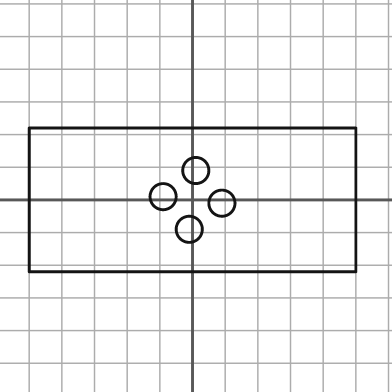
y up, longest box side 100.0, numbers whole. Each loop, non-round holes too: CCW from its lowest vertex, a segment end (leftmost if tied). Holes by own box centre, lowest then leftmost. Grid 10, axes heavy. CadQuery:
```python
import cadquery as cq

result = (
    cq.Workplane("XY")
    .moveTo(-50.0, -22.0)
    .lineTo(50.0, -22.0)
    .lineTo(50.0, 22.0)
    .lineTo(-50.0, 22.0)
    .close()
    .moveTo(-1.0, -9.0)
    .circle(4.0)
    .moveTo(9.0, -1.0)
    .circle(4.0)
    .moveTo(-9.0, 1.0)
    .circle(4.0)
    .moveTo(1.0, 9.0)
    .circle(4.0)
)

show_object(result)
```